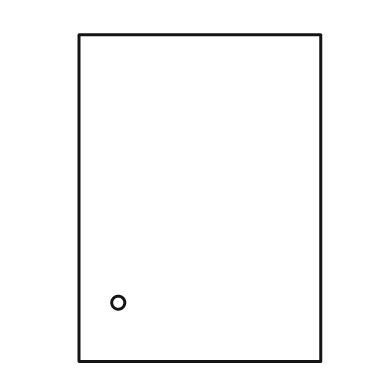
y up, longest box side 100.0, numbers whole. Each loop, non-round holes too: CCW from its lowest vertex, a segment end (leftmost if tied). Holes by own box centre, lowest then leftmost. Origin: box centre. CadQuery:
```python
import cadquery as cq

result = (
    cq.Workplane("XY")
    .moveTo(-37.0, -50.0)
    .lineTo(37.0, -50.0)
    .lineTo(37.0, 50.0)
    .lineTo(-37.0, 50.0)
    .close()
    .moveTo(-25.0, -32.0)
    .circle(2.0)
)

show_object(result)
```